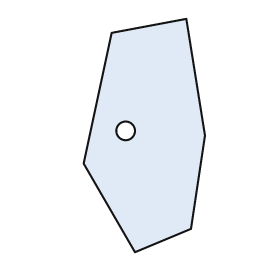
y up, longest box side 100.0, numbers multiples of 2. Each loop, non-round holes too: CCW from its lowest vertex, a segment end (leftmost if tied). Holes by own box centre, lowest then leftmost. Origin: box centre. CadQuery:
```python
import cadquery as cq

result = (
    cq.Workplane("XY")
    .moveTo(-4.0, -50.0)
    .lineTo(20.0, -40.0)
    .lineTo(26.0, 0.0)
    .lineTo(18.0, 50.0)
    .lineTo(-14.0, 44.0)
    .lineTo(-26.0, -12.0)
    .close()
    .moveTo(-8.0, 2.0)
    .circle(4.0)
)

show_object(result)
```